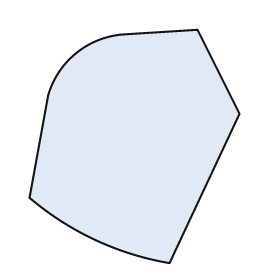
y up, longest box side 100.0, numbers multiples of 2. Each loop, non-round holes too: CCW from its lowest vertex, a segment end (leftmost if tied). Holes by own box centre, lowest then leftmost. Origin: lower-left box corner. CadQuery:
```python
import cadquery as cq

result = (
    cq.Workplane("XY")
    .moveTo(60.0, 0.0)
    .lineTo(90.0, 64.0)
    .lineTo(72.0, 100.0)
    .lineTo(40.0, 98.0)
    .threePointArc((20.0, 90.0), (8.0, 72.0))
    .lineTo(0.0, 28.0)
    .threePointArc((28.0, 10.0), (60.0, 0.0))
    .close()
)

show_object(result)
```